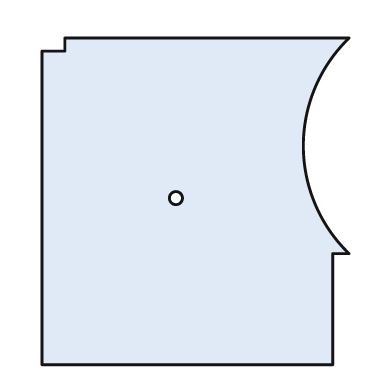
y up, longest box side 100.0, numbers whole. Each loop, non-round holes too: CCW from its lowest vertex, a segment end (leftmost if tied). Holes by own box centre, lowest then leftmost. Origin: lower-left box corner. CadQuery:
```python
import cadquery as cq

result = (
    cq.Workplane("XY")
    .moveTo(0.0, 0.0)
    .lineTo(89.0, 0.0)
    .lineTo(89.0, 34.0)
    .lineTo(94.0, 34.0)
    .threePointArc((80.0, 67.0), (94.0, 100.0))
    .lineTo(7.0, 100.0)
    .lineTo(7.0, 96.0)
    .lineTo(0.0, 96.0)
    .close()
    .moveTo(41.0, 51.0)
    .circle(2.0)
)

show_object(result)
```